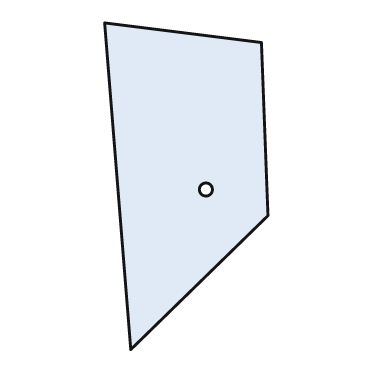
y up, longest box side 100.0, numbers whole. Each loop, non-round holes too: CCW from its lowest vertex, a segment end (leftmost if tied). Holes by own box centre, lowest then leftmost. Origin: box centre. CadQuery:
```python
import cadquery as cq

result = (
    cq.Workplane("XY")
    .moveTo(-17.0, -50.0)
    .lineTo(25.0, -9.0)
    .lineTo(23.0, 44.0)
    .lineTo(-25.0, 50.0)
    .close()
    .moveTo(6.0, -1.0)
    .circle(2.0)
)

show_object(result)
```